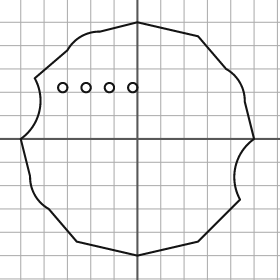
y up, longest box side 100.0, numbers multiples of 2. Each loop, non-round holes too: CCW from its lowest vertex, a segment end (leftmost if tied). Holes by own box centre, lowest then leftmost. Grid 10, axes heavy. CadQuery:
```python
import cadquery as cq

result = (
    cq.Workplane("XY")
    .moveTo(0.0, -50.0)
    .lineTo(26.0, -44.0)
    .lineTo(44.0, -26.0)
    .threePointArc((42.0, -12.0), (50.0, 0.0))
    .lineTo(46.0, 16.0)
    .threePointArc((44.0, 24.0), (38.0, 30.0))
    .lineTo(26.0, 44.0)
    .lineTo(0.0, 50.0)
    .lineTo(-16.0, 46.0)
    .threePointArc((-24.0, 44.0), (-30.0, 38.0))
    .lineTo(-44.0, 26.0)
    .threePointArc((-42.0, 12.0), (-50.0, 0.0))
    .lineTo(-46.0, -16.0)
    .threePointArc((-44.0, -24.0), (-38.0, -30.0))
    .lineTo(-26.0, -44.0)
    .close()
    .moveTo(-32.0, 22.0)
    .circle(2.0)
    .moveTo(-22.0, 22.0)
    .circle(2.0)
    .moveTo(-12.0, 22.0)
    .circle(2.0)
    .moveTo(-2.0, 22.0)
    .circle(2.0)
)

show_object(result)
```